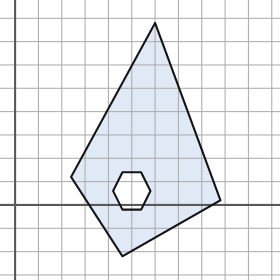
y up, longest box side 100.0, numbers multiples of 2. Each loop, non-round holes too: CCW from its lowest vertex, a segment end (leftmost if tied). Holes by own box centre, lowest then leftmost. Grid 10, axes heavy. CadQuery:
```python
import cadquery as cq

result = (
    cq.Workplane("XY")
    .moveTo(46.0, -22.0)
    .lineTo(88.0, 2.0)
    .lineTo(60.0, 78.0)
    .lineTo(24.0, 12.0)
    .close()
    .moveTo(46.0, -2.0)
    .lineTo(54.0, -2.0)
    .lineTo(58.0, 6.0)
    .lineTo(54.0, 14.0)
    .lineTo(46.0, 14.0)
    .lineTo(42.0, 6.0)
    .close()
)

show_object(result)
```